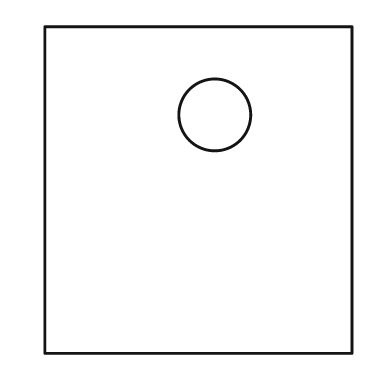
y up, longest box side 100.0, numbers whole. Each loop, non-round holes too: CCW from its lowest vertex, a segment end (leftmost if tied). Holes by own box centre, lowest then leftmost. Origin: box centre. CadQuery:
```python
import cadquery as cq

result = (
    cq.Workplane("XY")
    .moveTo(-47.0, -50.0)
    .lineTo(47.0, -50.0)
    .lineTo(47.0, 50.0)
    .lineTo(-47.0, 50.0)
    .close()
    .moveTo(5.0, 23.0)
    .circle(11.0)
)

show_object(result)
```